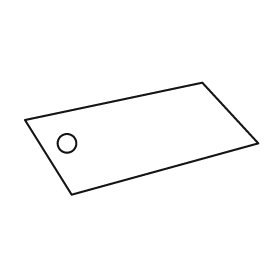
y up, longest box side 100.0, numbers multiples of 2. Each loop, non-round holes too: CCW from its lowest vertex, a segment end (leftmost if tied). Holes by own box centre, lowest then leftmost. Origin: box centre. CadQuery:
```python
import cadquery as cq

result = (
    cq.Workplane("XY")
    .moveTo(-30.0, -24.0)
    .lineTo(50.0, -2.0)
    .lineTo(26.0, 24.0)
    .lineTo(-50.0, 8.0)
    .close()
    .moveTo(-32.0, -2.0)
    .circle(4.0)
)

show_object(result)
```